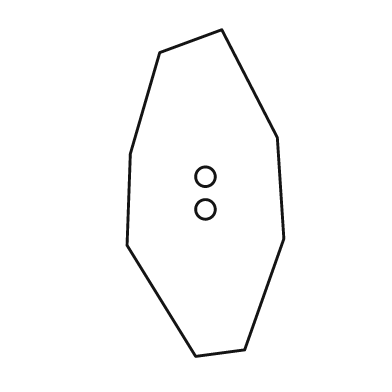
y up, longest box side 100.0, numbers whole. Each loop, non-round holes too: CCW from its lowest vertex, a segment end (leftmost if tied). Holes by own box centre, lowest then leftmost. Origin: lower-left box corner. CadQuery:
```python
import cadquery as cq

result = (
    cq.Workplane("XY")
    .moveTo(21.0, 0.0)
    .lineTo(36.0, 2.0)
    .lineTo(48.0, 36.0)
    .lineTo(46.0, 67.0)
    .lineTo(29.0, 100.0)
    .lineTo(10.0, 93.0)
    .lineTo(1.0, 62.0)
    .lineTo(0.0, 34.0)
    .close()
    .moveTo(24.0, 45.0)
    .circle(3.0)
    .moveTo(24.0, 55.0)
    .circle(3.0)
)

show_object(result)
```